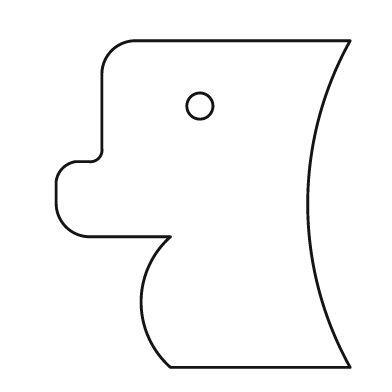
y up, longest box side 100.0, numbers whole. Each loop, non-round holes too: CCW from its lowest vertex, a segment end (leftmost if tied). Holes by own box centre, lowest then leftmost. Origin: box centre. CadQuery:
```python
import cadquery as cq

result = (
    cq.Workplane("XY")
    .moveTo(-10.0, -50.0)
    .lineTo(45.0, -50.0)
    .threePointArc((32.0, 0.0), (45.0, 50.0))
    .lineTo(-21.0, 50.0)
    .threePointArc((-28.0, 47.0), (-31.0, 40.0))
    .lineTo(-31.0, 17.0)
    .threePointArc((-32.0, 14.0), (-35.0, 13.0))
    .lineTo(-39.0, 13.0)
    .threePointArc((-43.0, 11.0), (-45.0, 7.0))
    .lineTo(-45.0, 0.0)
    .threePointArc((-42.0, -7.0), (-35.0, -10.0))
    .lineTo(-10.0, -10.0)
    .threePointArc((-19.0, -30.0), (-10.0, -50.0))
    .close()
    .moveTo(-1.0, 30.0)
    .circle(4.0)
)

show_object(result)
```